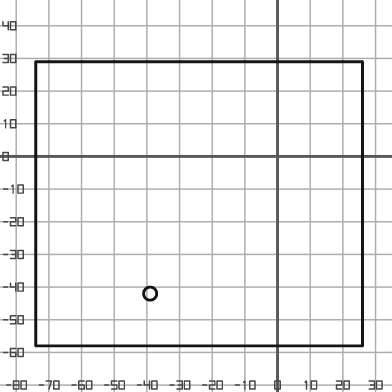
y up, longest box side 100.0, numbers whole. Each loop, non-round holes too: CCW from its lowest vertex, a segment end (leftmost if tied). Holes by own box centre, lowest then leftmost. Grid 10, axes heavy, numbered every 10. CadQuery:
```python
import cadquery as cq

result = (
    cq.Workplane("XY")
    .moveTo(-74.0, -58.0)
    .lineTo(26.0, -58.0)
    .lineTo(26.0, 29.0)
    .lineTo(-74.0, 29.0)
    .close()
    .moveTo(-39.0, -42.0)
    .circle(2.0)
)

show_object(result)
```